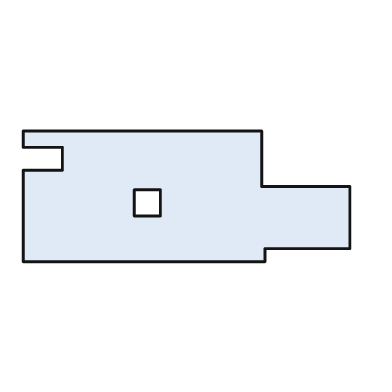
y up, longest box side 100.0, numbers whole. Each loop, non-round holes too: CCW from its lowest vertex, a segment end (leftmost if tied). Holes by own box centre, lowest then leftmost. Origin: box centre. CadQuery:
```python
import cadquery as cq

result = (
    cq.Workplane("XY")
    .moveTo(-50.0, -20.0)
    .lineTo(24.0, -20.0)
    .lineTo(24.0, -16.0)
    .lineTo(50.0, -16.0)
    .lineTo(50.0, 3.0)
    .lineTo(23.0, 3.0)
    .lineTo(23.0, 20.0)
    .lineTo(-50.0, 20.0)
    .lineTo(-50.0, 15.0)
    .lineTo(-38.0, 15.0)
    .lineTo(-38.0, 8.0)
    .lineTo(-50.0, 8.0)
    .close()
    .moveTo(-16.0, -6.0)
    .lineTo(-8.0, -6.0)
    .lineTo(-8.0, 2.0)
    .lineTo(-16.0, 2.0)
    .close()
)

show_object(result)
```